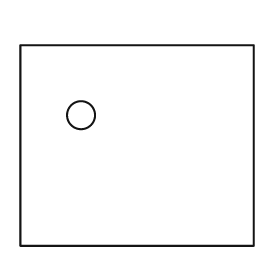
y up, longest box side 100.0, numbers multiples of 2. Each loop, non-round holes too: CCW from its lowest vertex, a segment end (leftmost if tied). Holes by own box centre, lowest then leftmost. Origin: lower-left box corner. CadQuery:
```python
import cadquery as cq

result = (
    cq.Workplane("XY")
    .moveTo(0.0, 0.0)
    .lineTo(100.0, 0.0)
    .lineTo(100.0, 86.0)
    .lineTo(0.0, 86.0)
    .close()
    .moveTo(26.0, 56.0)
    .circle(6.0)
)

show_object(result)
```